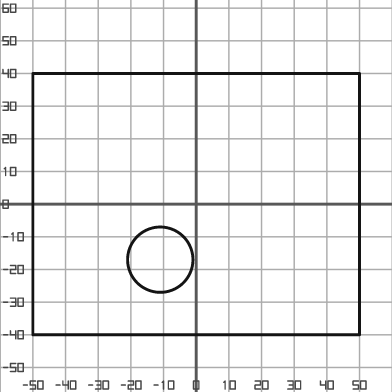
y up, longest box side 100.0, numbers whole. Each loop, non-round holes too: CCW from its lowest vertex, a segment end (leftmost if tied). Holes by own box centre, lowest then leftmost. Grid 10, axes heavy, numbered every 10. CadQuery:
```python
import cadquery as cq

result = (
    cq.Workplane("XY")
    .moveTo(-50.0, -40.0)
    .lineTo(50.0, -40.0)
    .lineTo(50.0, 40.0)
    .lineTo(-50.0, 40.0)
    .close()
    .moveTo(-11.0, -17.0)
    .circle(10.0)
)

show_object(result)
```